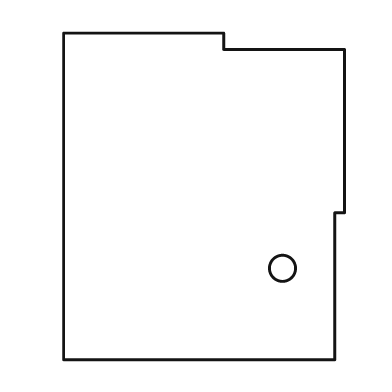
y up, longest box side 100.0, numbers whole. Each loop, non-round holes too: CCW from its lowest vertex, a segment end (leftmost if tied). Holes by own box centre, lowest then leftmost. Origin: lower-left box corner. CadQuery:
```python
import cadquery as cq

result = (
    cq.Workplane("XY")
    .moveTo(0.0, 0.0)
    .lineTo(83.0, 0.0)
    .lineTo(83.0, 45.0)
    .lineTo(86.0, 45.0)
    .lineTo(86.0, 95.0)
    .lineTo(49.0, 95.0)
    .lineTo(49.0, 100.0)
    .lineTo(0.0, 100.0)
    .close()
    .moveTo(67.0, 28.0)
    .circle(4.0)
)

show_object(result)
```